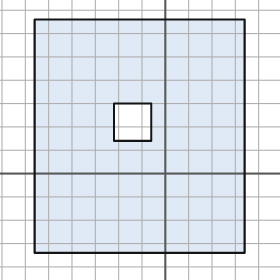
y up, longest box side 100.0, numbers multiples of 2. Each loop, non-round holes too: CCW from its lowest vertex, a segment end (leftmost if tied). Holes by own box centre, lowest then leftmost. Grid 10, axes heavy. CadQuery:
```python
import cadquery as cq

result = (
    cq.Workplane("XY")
    .moveTo(-56.0, -34.0)
    .lineTo(34.0, -34.0)
    .lineTo(34.0, 66.0)
    .lineTo(-56.0, 66.0)
    .close()
    .moveTo(-22.0, 14.0)
    .lineTo(-6.0, 14.0)
    .lineTo(-6.0, 30.0)
    .lineTo(-22.0, 30.0)
    .close()
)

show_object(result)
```